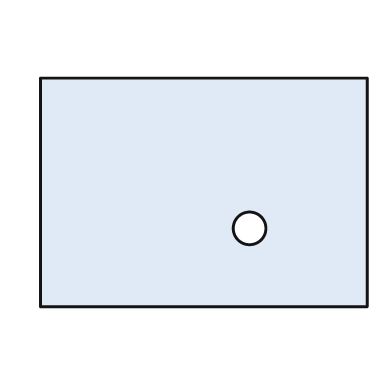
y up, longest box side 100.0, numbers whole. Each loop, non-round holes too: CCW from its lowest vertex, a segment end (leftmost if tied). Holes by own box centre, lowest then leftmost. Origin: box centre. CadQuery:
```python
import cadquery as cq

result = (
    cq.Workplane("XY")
    .moveTo(-50.0, -35.0)
    .lineTo(50.0, -35.0)
    .lineTo(50.0, 35.0)
    .lineTo(-50.0, 35.0)
    .close()
    .moveTo(14.0, -11.0)
    .circle(5.0)
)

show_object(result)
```